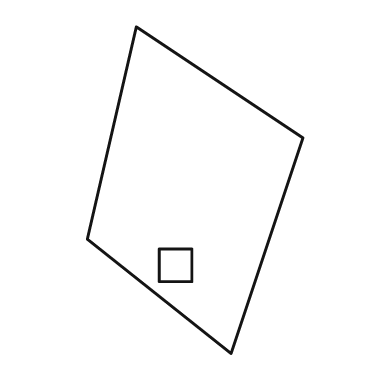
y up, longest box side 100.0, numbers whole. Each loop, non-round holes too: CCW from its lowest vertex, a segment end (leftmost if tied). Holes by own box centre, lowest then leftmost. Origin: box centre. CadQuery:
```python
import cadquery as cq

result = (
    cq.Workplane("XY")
    .moveTo(11.0, -50.0)
    .lineTo(33.0, 16.0)
    .lineTo(-18.0, 50.0)
    .lineTo(-33.0, -15.0)
    .close()
    .moveTo(-11.0, -28.0)
    .lineTo(-1.0, -28.0)
    .lineTo(-1.0, -18.0)
    .lineTo(-11.0, -18.0)
    .close()
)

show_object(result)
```